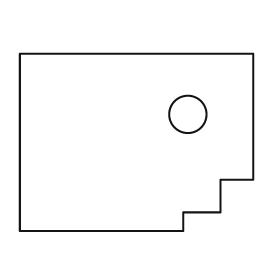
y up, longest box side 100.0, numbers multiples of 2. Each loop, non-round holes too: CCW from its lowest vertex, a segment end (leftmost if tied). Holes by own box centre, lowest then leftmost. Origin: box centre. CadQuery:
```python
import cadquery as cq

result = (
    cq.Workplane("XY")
    .moveTo(-50.0, -38.0)
    .lineTo(20.0, -38.0)
    .lineTo(20.0, -30.0)
    .lineTo(36.0, -30.0)
    .lineTo(36.0, -16.0)
    .lineTo(50.0, -16.0)
    .lineTo(50.0, 38.0)
    .lineTo(-50.0, 38.0)
    .close()
    .moveTo(22.0, 12.0)
    .circle(8.0)
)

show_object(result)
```